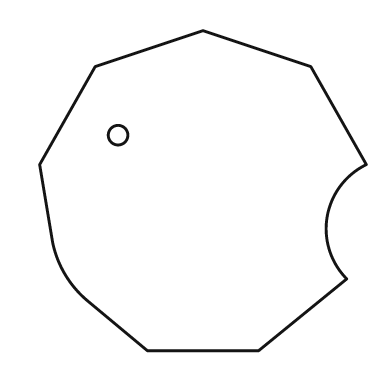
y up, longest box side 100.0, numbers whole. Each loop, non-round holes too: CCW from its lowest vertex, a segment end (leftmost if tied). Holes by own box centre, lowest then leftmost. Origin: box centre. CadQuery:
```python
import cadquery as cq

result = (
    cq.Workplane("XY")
    .moveTo(-17.0, -49.0)
    .lineTo(17.0, -49.0)
    .lineTo(44.0, -27.0)
    .threePointArc((38.0, -8.0), (50.0, 8.0))
    .lineTo(33.0, 38.0)
    .lineTo(0.0, 49.0)
    .lineTo(-33.0, 38.0)
    .lineTo(-50.0, 8.0)
    .lineTo(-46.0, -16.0)
    .threePointArc((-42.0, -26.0), (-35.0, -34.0))
    .close()
    .moveTo(-26.0, 17.0)
    .circle(3.0)
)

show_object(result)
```